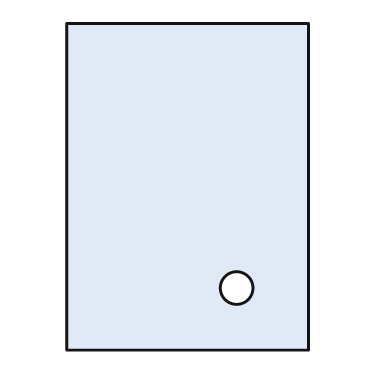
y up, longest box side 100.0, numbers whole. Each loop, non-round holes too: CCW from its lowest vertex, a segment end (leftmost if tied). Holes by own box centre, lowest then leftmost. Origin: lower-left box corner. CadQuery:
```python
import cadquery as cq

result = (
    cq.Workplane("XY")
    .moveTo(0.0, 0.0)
    .lineTo(74.0, 0.0)
    .lineTo(74.0, 100.0)
    .lineTo(0.0, 100.0)
    .close()
    .moveTo(52.0, 19.0)
    .circle(5.0)
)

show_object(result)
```